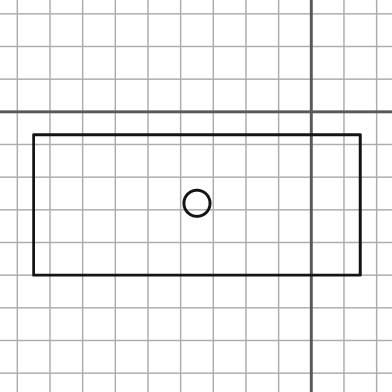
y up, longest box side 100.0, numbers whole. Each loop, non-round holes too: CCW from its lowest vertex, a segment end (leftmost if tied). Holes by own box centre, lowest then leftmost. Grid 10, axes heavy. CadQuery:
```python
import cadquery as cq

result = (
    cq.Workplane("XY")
    .moveTo(-85.0, -50.0)
    .lineTo(15.0, -50.0)
    .lineTo(15.0, -7.0)
    .lineTo(-85.0, -7.0)
    .close()
    .moveTo(-35.0, -28.0)
    .circle(4.0)
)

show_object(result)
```